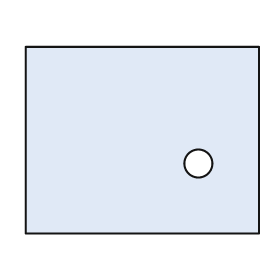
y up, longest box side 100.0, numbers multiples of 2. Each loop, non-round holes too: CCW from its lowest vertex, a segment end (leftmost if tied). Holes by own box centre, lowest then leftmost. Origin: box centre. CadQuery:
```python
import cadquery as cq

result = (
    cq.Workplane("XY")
    .moveTo(-50.0, -40.0)
    .lineTo(50.0, -40.0)
    .lineTo(50.0, 40.0)
    .lineTo(-50.0, 40.0)
    .close()
    .moveTo(24.0, -10.0)
    .circle(6.0)
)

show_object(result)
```